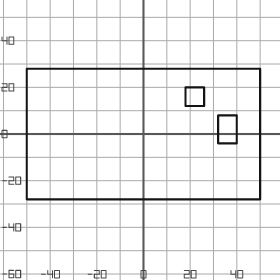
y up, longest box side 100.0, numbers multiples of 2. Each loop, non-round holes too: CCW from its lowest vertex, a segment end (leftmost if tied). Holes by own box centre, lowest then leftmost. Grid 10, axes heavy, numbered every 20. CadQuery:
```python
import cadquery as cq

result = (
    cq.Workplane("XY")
    .moveTo(-50.0, -28.0)
    .lineTo(50.0, -28.0)
    .lineTo(50.0, 28.0)
    .lineTo(-50.0, 28.0)
    .close()
    .moveTo(32.0, -4.0)
    .lineTo(40.0, -4.0)
    .lineTo(40.0, 8.0)
    .lineTo(32.0, 8.0)
    .close()
    .moveTo(18.0, 12.0)
    .lineTo(26.0, 12.0)
    .lineTo(26.0, 20.0)
    .lineTo(18.0, 20.0)
    .close()
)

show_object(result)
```